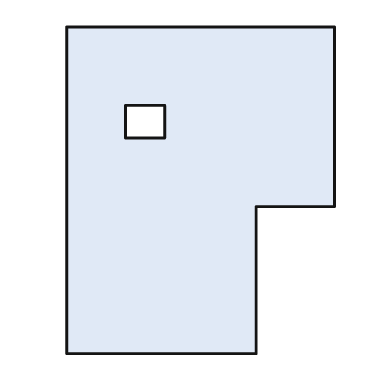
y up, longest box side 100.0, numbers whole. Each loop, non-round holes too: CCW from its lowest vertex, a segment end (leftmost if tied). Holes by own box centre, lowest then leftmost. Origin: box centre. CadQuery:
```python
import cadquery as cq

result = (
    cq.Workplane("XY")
    .moveTo(-41.0, -50.0)
    .lineTo(17.0, -50.0)
    .lineTo(17.0, -5.0)
    .lineTo(41.0, -5.0)
    .lineTo(41.0, 50.0)
    .lineTo(-41.0, 50.0)
    .close()
    .moveTo(-23.0, 16.0)
    .lineTo(-11.0, 16.0)
    .lineTo(-11.0, 26.0)
    .lineTo(-23.0, 26.0)
    .close()
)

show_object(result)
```